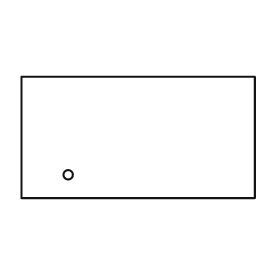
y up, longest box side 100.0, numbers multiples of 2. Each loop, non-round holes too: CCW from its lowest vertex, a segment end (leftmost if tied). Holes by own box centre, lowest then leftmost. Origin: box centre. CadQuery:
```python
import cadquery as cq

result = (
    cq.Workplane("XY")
    .moveTo(-50.0, -26.0)
    .lineTo(50.0, -26.0)
    .lineTo(50.0, 26.0)
    .lineTo(-50.0, 26.0)
    .close()
    .moveTo(-30.0, -16.0)
    .circle(2.0)
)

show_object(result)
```